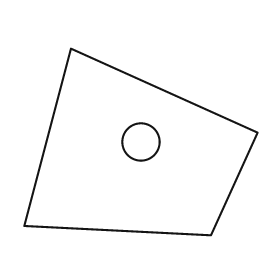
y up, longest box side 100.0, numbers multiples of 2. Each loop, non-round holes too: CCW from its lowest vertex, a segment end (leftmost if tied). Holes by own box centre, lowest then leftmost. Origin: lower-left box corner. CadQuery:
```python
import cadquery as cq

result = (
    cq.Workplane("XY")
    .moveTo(80.0, 0.0)
    .lineTo(100.0, 44.0)
    .lineTo(20.0, 80.0)
    .lineTo(0.0, 4.0)
    .close()
    .moveTo(50.0, 40.0)
    .circle(8.0)
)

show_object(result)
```